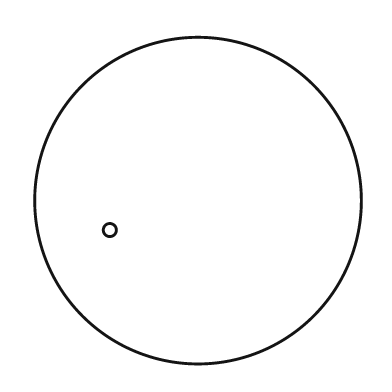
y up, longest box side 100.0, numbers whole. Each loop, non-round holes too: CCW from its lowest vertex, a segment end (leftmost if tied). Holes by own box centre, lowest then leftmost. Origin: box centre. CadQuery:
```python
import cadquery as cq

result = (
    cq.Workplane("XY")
    .moveTo(0.0, 0.0)
    .circle(50.0)
    .moveTo(-27.0, -9.0)
    .circle(2.0)
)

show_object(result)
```